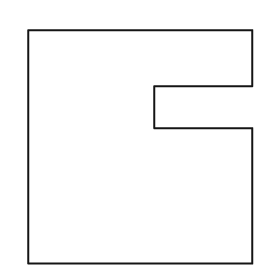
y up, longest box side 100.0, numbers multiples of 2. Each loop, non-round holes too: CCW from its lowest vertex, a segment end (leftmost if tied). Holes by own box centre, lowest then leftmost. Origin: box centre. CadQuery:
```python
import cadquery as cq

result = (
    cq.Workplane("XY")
    .moveTo(-48.0, -50.0)
    .lineTo(48.0, -50.0)
    .lineTo(48.0, 8.0)
    .lineTo(6.0, 8.0)
    .lineTo(6.0, 26.0)
    .lineTo(48.0, 26.0)
    .lineTo(48.0, 50.0)
    .lineTo(-48.0, 50.0)
    .close()
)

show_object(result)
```